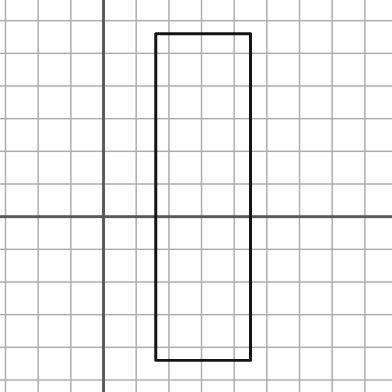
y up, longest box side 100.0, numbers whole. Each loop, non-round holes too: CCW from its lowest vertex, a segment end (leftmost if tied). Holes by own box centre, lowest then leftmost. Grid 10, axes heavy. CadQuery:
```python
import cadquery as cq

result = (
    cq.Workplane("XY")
    .moveTo(16.0, -44.0)
    .lineTo(45.0, -44.0)
    .lineTo(45.0, 56.0)
    .lineTo(16.0, 56.0)
    .close()
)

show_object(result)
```